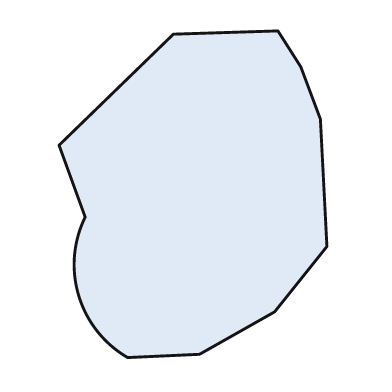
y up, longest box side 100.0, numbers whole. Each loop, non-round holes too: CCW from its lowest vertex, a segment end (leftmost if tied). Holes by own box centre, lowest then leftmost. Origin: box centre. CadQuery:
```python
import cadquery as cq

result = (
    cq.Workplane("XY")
    .moveTo(-20.0, -50.0)
    .lineTo(2.0, -49.0)
    .lineTo(25.0, -36.0)
    .lineTo(41.0, -16.0)
    .lineTo(39.0, 23.0)
    .lineTo(33.0, 39.0)
    .lineTo(26.0, 50.0)
    .lineTo(-6.0, 49.0)
    .lineTo(-41.0, 15.0)
    .lineTo(-33.0, -7.0)
    .threePointArc((-35.0, -31.0), (-20.0, -50.0))
    .close()
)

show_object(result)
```